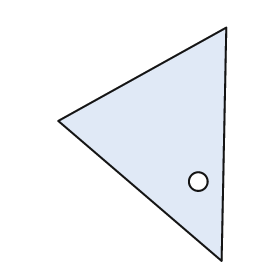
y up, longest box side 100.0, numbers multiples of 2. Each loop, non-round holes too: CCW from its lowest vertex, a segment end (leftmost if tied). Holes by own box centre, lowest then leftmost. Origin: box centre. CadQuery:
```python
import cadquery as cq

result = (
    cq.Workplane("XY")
    .moveTo(34.0, -50.0)
    .lineTo(36.0, 50.0)
    .lineTo(-36.0, 10.0)
    .close()
    .moveTo(24.0, -16.0)
    .circle(4.0)
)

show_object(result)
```